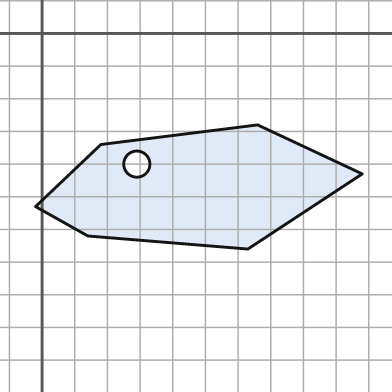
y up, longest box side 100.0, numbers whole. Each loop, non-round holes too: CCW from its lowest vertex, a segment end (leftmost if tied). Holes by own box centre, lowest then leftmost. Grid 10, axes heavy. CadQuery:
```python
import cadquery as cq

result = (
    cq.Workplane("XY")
    .moveTo(63.0, -66.0)
    .lineTo(98.0, -43.0)
    .lineTo(66.0, -28.0)
    .lineTo(18.0, -34.0)
    .lineTo(-2.0, -53.0)
    .lineTo(14.0, -62.0)
    .close()
    .moveTo(29.0, -40.0)
    .circle(4.0)
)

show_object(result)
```